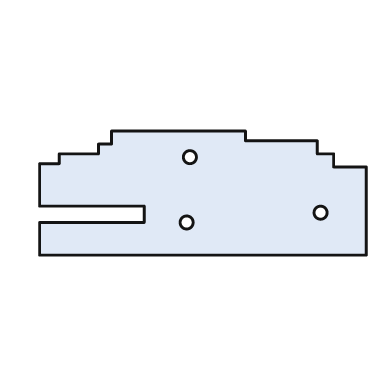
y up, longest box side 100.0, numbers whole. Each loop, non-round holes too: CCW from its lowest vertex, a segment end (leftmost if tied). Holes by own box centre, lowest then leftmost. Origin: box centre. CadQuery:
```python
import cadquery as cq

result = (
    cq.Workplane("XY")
    .moveTo(-50.0, -19.0)
    .lineTo(50.0, -19.0)
    .lineTo(50.0, 8.0)
    .lineTo(40.0, 8.0)
    .lineTo(40.0, 12.0)
    .lineTo(35.0, 12.0)
    .lineTo(35.0, 16.0)
    .lineTo(13.0, 16.0)
    .lineTo(13.0, 19.0)
    .lineTo(-28.0, 19.0)
    .lineTo(-28.0, 15.0)
    .lineTo(-32.0, 15.0)
    .lineTo(-32.0, 12.0)
    .lineTo(-44.0, 12.0)
    .lineTo(-44.0, 9.0)
    .lineTo(-50.0, 9.0)
    .lineTo(-50.0, -4.0)
    .lineTo(-18.0, -4.0)
    .lineTo(-18.0, -9.0)
    .lineTo(-50.0, -9.0)
    .close()
    .moveTo(-5.0, -9.0)
    .circle(2.0)
    .moveTo(36.0, -6.0)
    .circle(2.0)
    .moveTo(-4.0, 11.0)
    .circle(2.0)
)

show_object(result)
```